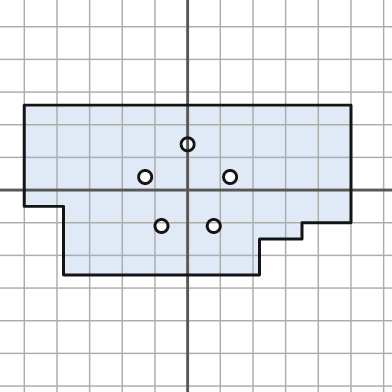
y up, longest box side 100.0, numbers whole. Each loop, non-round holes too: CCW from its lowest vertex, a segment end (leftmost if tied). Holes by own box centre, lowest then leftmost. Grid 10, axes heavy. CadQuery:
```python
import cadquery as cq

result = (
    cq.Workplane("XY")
    .moveTo(-38.0, -26.0)
    .lineTo(22.0, -26.0)
    .lineTo(22.0, -15.0)
    .lineTo(35.0, -15.0)
    .lineTo(35.0, -10.0)
    .lineTo(50.0, -10.0)
    .lineTo(50.0, 26.0)
    .lineTo(-50.0, 26.0)
    .lineTo(-50.0, -5.0)
    .lineTo(-38.0, -5.0)
    .close()
    .moveTo(-8.0, -11.0)
    .circle(2.0)
    .moveTo(8.0, -11.0)
    .circle(2.0)
    .moveTo(-13.0, 4.0)
    .circle(2.0)
    .moveTo(13.0, 4.0)
    .circle(2.0)
    .moveTo(0.0, 14.0)
    .circle(2.0)
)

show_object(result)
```